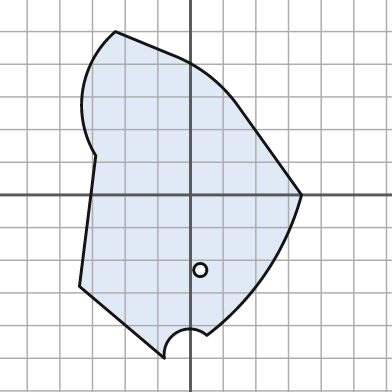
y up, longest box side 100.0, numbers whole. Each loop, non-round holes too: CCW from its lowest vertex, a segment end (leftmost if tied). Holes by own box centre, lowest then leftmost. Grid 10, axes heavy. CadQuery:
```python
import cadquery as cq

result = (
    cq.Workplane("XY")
    .moveTo(-8.0, -50.0)
    .threePointArc((-4.0, -42.0), (5.0, -43.0))
    .threePointArc((23.0, -24.0), (34.0, 0.0))
    .lineTo(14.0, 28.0)
    .threePointArc((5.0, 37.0), (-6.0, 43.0))
    .lineTo(-23.0, 50.0)
    .threePointArc((-33.0, 32.0), (-29.0, 12.0))
    .lineTo(-34.0, -28.0)
    .close()
    .moveTo(3.0, -23.0)
    .circle(2.0)
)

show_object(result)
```